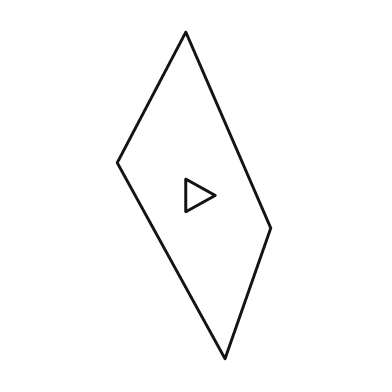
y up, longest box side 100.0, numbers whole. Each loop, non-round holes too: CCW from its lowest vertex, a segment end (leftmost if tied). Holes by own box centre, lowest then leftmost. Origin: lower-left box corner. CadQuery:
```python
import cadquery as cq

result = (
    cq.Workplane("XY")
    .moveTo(33.0, 0.0)
    .lineTo(47.0, 40.0)
    .lineTo(21.0, 100.0)
    .lineTo(0.0, 60.0)
    .close()
    .moveTo(21.0, 45.0)
    .lineTo(30.0, 50.0)
    .lineTo(21.0, 55.0)
    .close()
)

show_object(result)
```